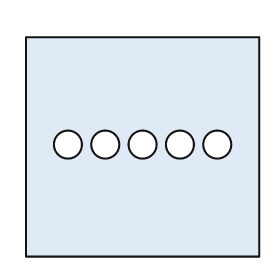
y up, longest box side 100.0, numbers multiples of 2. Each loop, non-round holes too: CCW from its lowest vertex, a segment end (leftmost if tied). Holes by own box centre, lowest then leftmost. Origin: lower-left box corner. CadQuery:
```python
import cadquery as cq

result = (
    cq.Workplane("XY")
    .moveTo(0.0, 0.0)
    .lineTo(100.0, 0.0)
    .lineTo(100.0, 94.0)
    .lineTo(0.0, 94.0)
    .close()
    .moveTo(18.0, 48.0)
    .circle(6.0)
    .moveTo(34.0, 48.0)
    .circle(6.0)
    .moveTo(50.0, 48.0)
    .circle(6.0)
    .moveTo(66.0, 48.0)
    .circle(6.0)
    .moveTo(82.0, 48.0)
    .circle(6.0)
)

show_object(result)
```